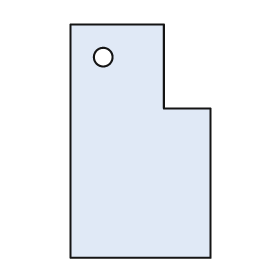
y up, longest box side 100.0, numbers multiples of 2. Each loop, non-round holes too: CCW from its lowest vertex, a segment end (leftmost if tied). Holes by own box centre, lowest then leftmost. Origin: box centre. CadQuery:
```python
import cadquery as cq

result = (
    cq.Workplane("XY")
    .moveTo(-30.0, -50.0)
    .lineTo(30.0, -50.0)
    .lineTo(30.0, 14.0)
    .lineTo(10.0, 14.0)
    .lineTo(10.0, 50.0)
    .lineTo(-30.0, 50.0)
    .close()
    .moveTo(-16.0, 36.0)
    .circle(4.0)
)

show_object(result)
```